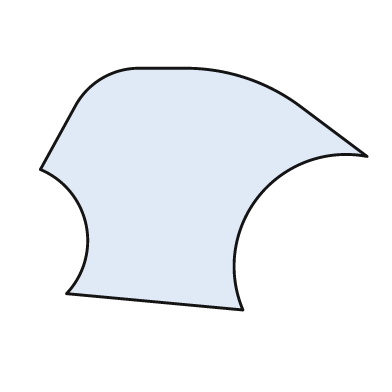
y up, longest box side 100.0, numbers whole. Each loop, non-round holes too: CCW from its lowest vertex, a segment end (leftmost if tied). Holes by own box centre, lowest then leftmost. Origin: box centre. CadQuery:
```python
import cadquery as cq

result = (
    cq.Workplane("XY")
    .moveTo(12.0, -37.0)
    .threePointArc((17.0, -2.0), (50.0, 10.0))
    .lineTo(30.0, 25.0)
    .threePointArc((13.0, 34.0), (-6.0, 37.0))
    .lineTo(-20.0, 37.0)
    .threePointArc((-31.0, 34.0), (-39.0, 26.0))
    .lineTo(-50.0, 6.0)
    .threePointArc((-36.0, -11.0), (-42.0, -32.0))
    .close()
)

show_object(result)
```